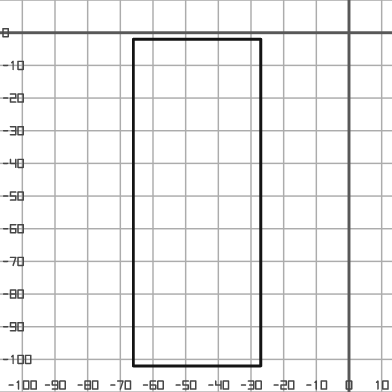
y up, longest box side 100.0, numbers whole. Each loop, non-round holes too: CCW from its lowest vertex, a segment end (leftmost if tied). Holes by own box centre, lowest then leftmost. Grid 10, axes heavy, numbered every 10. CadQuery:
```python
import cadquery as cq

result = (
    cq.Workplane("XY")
    .moveTo(-66.0, -102.0)
    .lineTo(-27.0, -102.0)
    .lineTo(-27.0, -2.0)
    .lineTo(-66.0, -2.0)
    .close()
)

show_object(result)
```